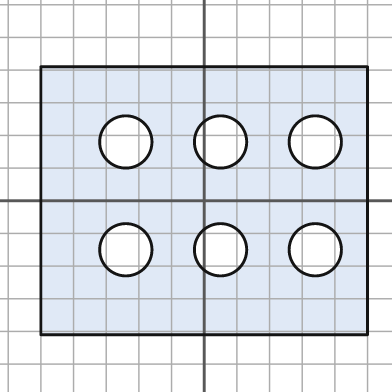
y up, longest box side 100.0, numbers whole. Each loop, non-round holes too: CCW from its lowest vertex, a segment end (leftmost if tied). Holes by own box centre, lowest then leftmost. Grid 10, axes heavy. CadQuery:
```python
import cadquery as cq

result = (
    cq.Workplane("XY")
    .moveTo(-50.0, -41.0)
    .lineTo(50.0, -41.0)
    .lineTo(50.0, 41.0)
    .lineTo(-50.0, 41.0)
    .close()
    .moveTo(-24.0, -15.0)
    .circle(8.0)
    .moveTo(5.0, -15.0)
    .circle(8.0)
    .moveTo(34.0, -15.0)
    .circle(8.0)
    .moveTo(-24.0, 18.0)
    .circle(8.0)
    .moveTo(5.0, 18.0)
    .circle(8.0)
    .moveTo(34.0, 18.0)
    .circle(8.0)
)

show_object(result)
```